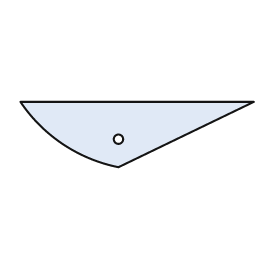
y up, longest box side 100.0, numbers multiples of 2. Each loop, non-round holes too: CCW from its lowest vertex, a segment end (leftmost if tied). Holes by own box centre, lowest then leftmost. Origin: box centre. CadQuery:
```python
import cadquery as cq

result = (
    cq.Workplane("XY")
    .moveTo(-8.0, -14.0)
    .lineTo(50.0, 14.0)
    .lineTo(-50.0, 14.0)
    .threePointArc((-32.0, -4.0), (-8.0, -14.0))
    .close()
    .moveTo(-8.0, -2.0)
    .circle(2.0)
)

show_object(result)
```